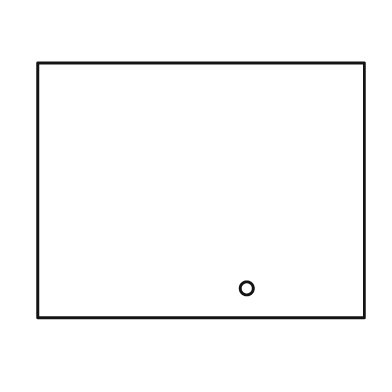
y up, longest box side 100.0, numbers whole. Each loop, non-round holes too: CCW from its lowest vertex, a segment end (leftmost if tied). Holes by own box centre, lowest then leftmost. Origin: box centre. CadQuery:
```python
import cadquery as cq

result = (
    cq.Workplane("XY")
    .moveTo(-50.0, -39.0)
    .lineTo(50.0, -39.0)
    .lineTo(50.0, 39.0)
    .lineTo(-50.0, 39.0)
    .close()
    .moveTo(14.0, -30.0)
    .circle(2.0)
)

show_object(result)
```